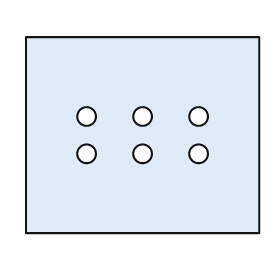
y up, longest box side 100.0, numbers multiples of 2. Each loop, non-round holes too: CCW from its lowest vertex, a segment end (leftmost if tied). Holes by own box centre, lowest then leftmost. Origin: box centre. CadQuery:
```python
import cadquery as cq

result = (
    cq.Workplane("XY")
    .moveTo(-50.0, -42.0)
    .lineTo(50.0, -42.0)
    .lineTo(50.0, 42.0)
    .lineTo(-50.0, 42.0)
    .close()
    .moveTo(-24.0, -8.0)
    .circle(4.0)
    .moveTo(0.0, -8.0)
    .circle(4.0)
    .moveTo(24.0, -8.0)
    .circle(4.0)
    .moveTo(-24.0, 8.0)
    .circle(4.0)
    .moveTo(0.0, 8.0)
    .circle(4.0)
    .moveTo(24.0, 8.0)
    .circle(4.0)
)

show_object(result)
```